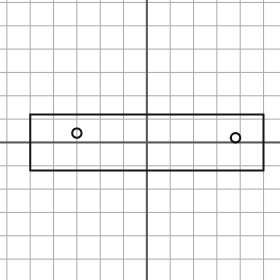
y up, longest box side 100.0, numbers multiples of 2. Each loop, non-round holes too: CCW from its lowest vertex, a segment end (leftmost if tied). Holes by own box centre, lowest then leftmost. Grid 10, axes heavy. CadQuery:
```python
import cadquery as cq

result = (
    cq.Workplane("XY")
    .moveTo(-50.0, -12.0)
    .lineTo(50.0, -12.0)
    .lineTo(50.0, 12.0)
    .lineTo(-50.0, 12.0)
    .close()
    .moveTo(38.0, 2.0)
    .circle(2.0)
    .moveTo(-30.0, 4.0)
    .circle(2.0)
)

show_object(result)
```